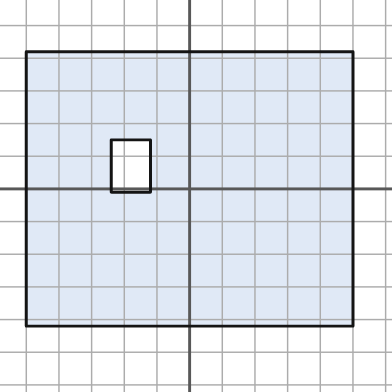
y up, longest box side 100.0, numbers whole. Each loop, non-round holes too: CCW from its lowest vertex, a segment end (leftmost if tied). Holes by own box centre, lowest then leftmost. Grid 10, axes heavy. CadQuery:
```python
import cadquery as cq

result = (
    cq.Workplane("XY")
    .moveTo(-50.0, -42.0)
    .lineTo(50.0, -42.0)
    .lineTo(50.0, 42.0)
    .lineTo(-50.0, 42.0)
    .close()
    .moveTo(-24.0, -1.0)
    .lineTo(-12.0, -1.0)
    .lineTo(-12.0, 15.0)
    .lineTo(-24.0, 15.0)
    .close()
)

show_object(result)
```